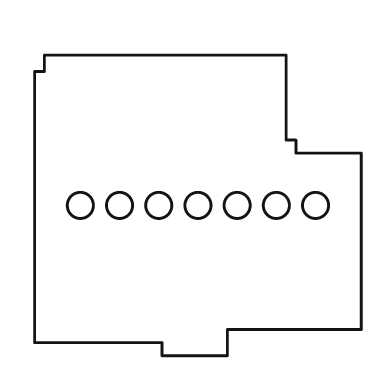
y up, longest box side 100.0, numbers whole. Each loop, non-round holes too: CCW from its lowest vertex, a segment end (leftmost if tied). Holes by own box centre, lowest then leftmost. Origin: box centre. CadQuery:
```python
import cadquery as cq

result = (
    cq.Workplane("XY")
    .moveTo(-11.0, -46.0)
    .lineTo(9.0, -46.0)
    .lineTo(9.0, -38.0)
    .lineTo(50.0, -38.0)
    .lineTo(50.0, 16.0)
    .lineTo(30.0, 16.0)
    .lineTo(30.0, 20.0)
    .lineTo(27.0, 20.0)
    .lineTo(27.0, 46.0)
    .lineTo(-47.0, 46.0)
    .lineTo(-47.0, 41.0)
    .lineTo(-50.0, 41.0)
    .lineTo(-50.0, -42.0)
    .lineTo(-11.0, -42.0)
    .close()
    .moveTo(-36.0, 0.0)
    .circle(4.0)
    .moveTo(-24.0, 0.0)
    .circle(4.0)
    .moveTo(-12.0, 0.0)
    .circle(4.0)
    .moveTo(0.0, 0.0)
    .circle(4.0)
    .moveTo(12.0, 0.0)
    .circle(4.0)
    .moveTo(24.0, 0.0)
    .circle(4.0)
    .moveTo(36.0, 0.0)
    .circle(4.0)
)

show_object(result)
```